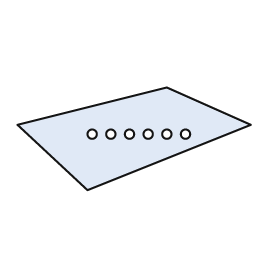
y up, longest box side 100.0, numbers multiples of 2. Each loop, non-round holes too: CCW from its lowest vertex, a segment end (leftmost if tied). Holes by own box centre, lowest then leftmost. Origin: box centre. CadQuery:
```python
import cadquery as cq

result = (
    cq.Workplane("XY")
    .moveTo(-20.0, -22.0)
    .lineTo(50.0, 6.0)
    .lineTo(14.0, 22.0)
    .lineTo(-50.0, 6.0)
    .close()
    .moveTo(-18.0, 2.0)
    .circle(2.0)
    .moveTo(-10.0, 2.0)
    .circle(2.0)
    .moveTo(-2.0, 2.0)
    .circle(2.0)
    .moveTo(6.0, 2.0)
    .circle(2.0)
    .moveTo(14.0, 2.0)
    .circle(2.0)
    .moveTo(22.0, 2.0)
    .circle(2.0)
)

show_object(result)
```